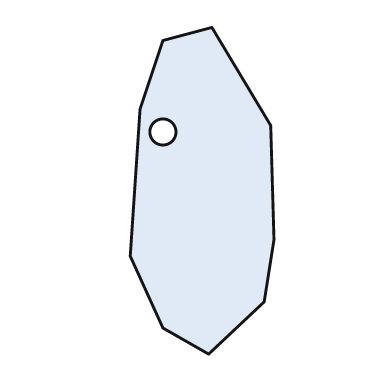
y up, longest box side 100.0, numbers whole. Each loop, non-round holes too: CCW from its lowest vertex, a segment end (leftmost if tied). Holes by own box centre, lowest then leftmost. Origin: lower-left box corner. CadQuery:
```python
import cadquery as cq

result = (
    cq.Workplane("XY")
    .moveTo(24.0, 0.0)
    .lineTo(41.0, 16.0)
    .lineTo(44.0, 35.0)
    .lineTo(43.0, 70.0)
    .lineTo(25.0, 100.0)
    .lineTo(10.0, 96.0)
    .lineTo(3.0, 75.0)
    .lineTo(0.0, 30.0)
    .lineTo(10.0, 8.0)
    .close()
    .moveTo(10.0, 68.0)
    .circle(4.0)
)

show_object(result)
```